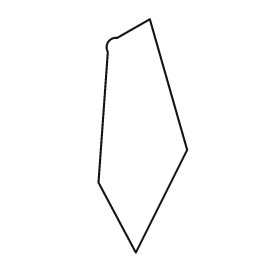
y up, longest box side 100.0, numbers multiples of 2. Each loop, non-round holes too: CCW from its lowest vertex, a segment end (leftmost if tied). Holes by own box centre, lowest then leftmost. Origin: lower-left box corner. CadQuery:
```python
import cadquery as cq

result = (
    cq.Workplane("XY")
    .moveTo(16.0, 0.0)
    .lineTo(38.0, 44.0)
    .lineTo(22.0, 100.0)
    .lineTo(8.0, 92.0)
    .threePointArc((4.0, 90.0), (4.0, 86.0))
    .lineTo(0.0, 30.0)
    .close()
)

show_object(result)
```